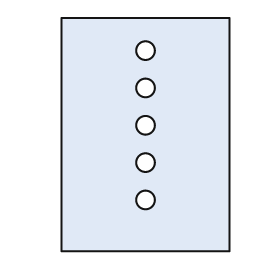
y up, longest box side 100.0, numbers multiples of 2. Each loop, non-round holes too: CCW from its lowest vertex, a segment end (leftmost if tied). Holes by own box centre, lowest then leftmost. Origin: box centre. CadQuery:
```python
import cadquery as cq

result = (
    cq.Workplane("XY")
    .moveTo(-36.0, -50.0)
    .lineTo(36.0, -50.0)
    .lineTo(36.0, 50.0)
    .lineTo(-36.0, 50.0)
    .close()
    .moveTo(0.0, -28.0)
    .circle(4.0)
    .moveTo(0.0, -12.0)
    .circle(4.0)
    .moveTo(0.0, 4.0)
    .circle(4.0)
    .moveTo(0.0, 20.0)
    .circle(4.0)
    .moveTo(0.0, 36.0)
    .circle(4.0)
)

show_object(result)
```